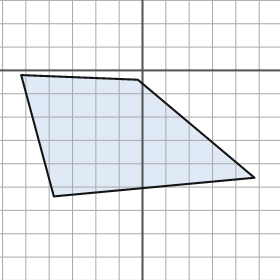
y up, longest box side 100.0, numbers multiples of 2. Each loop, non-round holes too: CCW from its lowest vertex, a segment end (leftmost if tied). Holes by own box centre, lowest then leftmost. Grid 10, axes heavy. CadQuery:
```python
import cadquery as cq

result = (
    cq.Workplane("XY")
    .moveTo(-38.0, -54.0)
    .lineTo(48.0, -46.0)
    .lineTo(-2.0, -4.0)
    .lineTo(-52.0, -2.0)
    .close()
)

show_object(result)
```